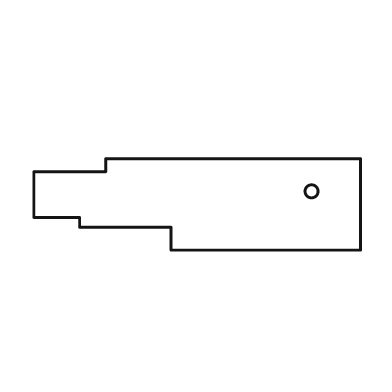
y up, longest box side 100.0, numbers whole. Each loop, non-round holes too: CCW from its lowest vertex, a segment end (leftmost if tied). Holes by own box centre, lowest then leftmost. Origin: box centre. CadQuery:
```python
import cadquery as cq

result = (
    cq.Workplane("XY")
    .moveTo(-8.0, -14.0)
    .lineTo(50.0, -14.0)
    .lineTo(50.0, 14.0)
    .lineTo(-28.0, 14.0)
    .lineTo(-28.0, 10.0)
    .lineTo(-50.0, 10.0)
    .lineTo(-50.0, -4.0)
    .lineTo(-36.0, -4.0)
    .lineTo(-36.0, -7.0)
    .lineTo(-8.0, -7.0)
    .close()
    .moveTo(35.0, 4.0)
    .circle(2.0)
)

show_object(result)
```